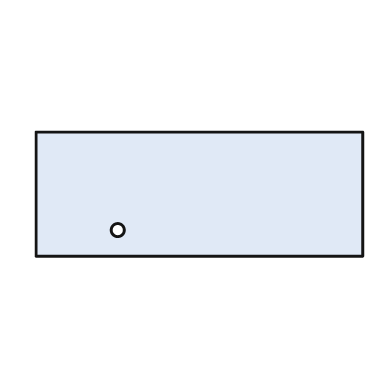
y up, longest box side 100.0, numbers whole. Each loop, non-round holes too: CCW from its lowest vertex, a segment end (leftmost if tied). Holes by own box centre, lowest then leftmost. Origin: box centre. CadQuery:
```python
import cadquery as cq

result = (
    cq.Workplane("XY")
    .moveTo(-50.0, -19.0)
    .lineTo(50.0, -19.0)
    .lineTo(50.0, 19.0)
    .lineTo(-50.0, 19.0)
    .close()
    .moveTo(-25.0, -11.0)
    .circle(2.0)
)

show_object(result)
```